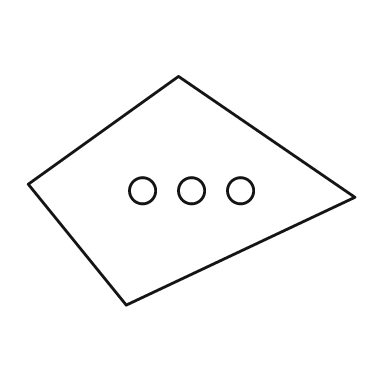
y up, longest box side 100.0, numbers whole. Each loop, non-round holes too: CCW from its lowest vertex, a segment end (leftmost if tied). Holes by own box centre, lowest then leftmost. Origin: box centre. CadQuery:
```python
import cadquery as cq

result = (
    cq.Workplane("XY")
    .moveTo(-20.0, -35.0)
    .lineTo(50.0, -2.0)
    .lineTo(-4.0, 35.0)
    .lineTo(-50.0, 2.0)
    .close()
    .moveTo(-15.0, 0.0)
    .circle(4.0)
    .moveTo(0.0, 0.0)
    .circle(4.0)
    .moveTo(15.0, 0.0)
    .circle(4.0)
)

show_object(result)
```